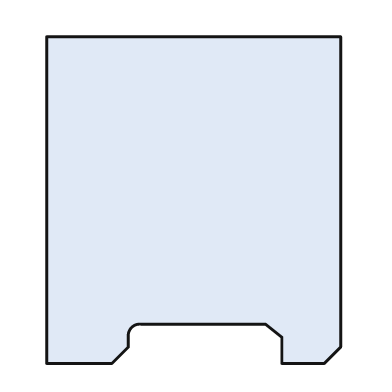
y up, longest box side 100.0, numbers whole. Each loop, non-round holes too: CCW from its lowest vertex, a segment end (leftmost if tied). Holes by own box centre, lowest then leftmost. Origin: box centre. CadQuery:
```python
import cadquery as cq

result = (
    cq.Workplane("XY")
    .moveTo(-45.0, -50.0)
    .lineTo(-25.0, -50.0)
    .lineTo(-20.0, -45.0)
    .lineTo(-20.0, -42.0)
    .threePointArc((-19.0, -39.0), (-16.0, -38.0))
    .lineTo(22.0, -38.0)
    .lineTo(27.0, -42.0)
    .lineTo(27.0, -50.0)
    .lineTo(40.0, -50.0)
    .lineTo(45.0, -45.0)
    .lineTo(45.0, 50.0)
    .lineTo(-45.0, 50.0)
    .close()
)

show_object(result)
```